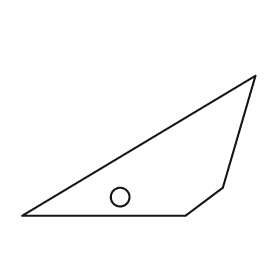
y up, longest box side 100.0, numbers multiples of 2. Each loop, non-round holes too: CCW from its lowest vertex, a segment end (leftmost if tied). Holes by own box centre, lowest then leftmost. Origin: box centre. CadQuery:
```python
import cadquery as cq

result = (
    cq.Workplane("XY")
    .moveTo(-50.0, -30.0)
    .lineTo(20.0, -30.0)
    .lineTo(36.0, -18.0)
    .lineTo(50.0, 30.0)
    .close()
    .moveTo(-8.0, -22.0)
    .circle(4.0)
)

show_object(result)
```